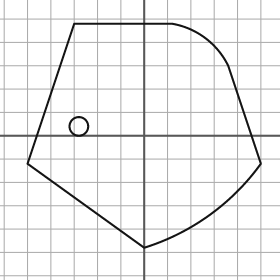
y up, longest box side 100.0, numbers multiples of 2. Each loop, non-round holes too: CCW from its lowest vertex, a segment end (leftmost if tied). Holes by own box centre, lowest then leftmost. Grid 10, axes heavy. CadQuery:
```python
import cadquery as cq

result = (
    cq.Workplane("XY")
    .moveTo(0.0, -48.0)
    .threePointArc((28.0, -34.0), (50.0, -12.0))
    .lineTo(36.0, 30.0)
    .threePointArc((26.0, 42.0), (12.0, 48.0))
    .lineTo(-30.0, 48.0)
    .lineTo(-50.0, -12.0)
    .close()
    .moveTo(-28.0, 4.0)
    .circle(4.0)
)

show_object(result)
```